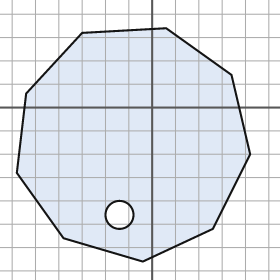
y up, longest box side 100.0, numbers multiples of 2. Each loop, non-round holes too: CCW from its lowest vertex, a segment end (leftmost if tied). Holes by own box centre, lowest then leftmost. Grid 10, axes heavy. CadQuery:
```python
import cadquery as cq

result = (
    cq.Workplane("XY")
    .moveTo(-4.0, -66.0)
    .lineTo(26.0, -52.0)
    .lineTo(42.0, -20.0)
    .lineTo(34.0, 14.0)
    .lineTo(6.0, 34.0)
    .lineTo(-30.0, 32.0)
    .lineTo(-54.0, 6.0)
    .lineTo(-58.0, -28.0)
    .lineTo(-38.0, -56.0)
    .close()
    .moveTo(-14.0, -46.0)
    .circle(6.0)
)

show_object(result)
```